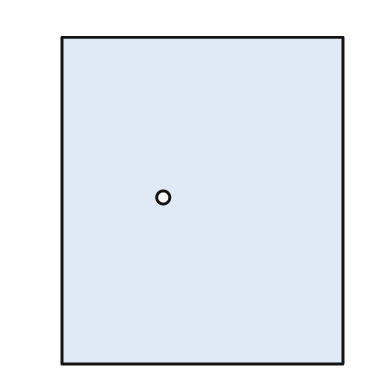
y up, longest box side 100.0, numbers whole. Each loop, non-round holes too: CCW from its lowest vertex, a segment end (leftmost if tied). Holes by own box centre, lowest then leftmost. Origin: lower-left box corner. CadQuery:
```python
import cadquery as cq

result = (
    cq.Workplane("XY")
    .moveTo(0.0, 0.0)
    .lineTo(86.0, 0.0)
    .lineTo(86.0, 100.0)
    .lineTo(0.0, 100.0)
    .close()
    .moveTo(31.0, 51.0)
    .circle(2.0)
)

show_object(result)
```